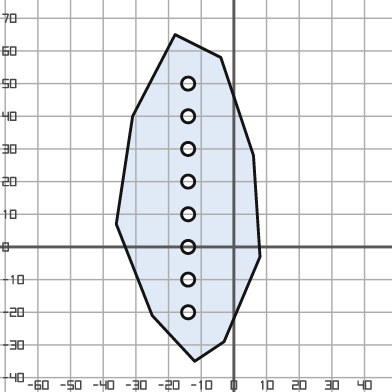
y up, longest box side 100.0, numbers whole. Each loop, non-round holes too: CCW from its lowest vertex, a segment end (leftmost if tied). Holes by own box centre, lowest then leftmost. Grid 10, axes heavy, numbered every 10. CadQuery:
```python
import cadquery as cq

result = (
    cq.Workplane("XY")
    .moveTo(-12.0, -35.0)
    .lineTo(-3.0, -29.0)
    .lineTo(8.0, -3.0)
    .lineTo(6.0, 28.0)
    .lineTo(-4.0, 58.0)
    .lineTo(-18.0, 65.0)
    .lineTo(-31.0, 40.0)
    .lineTo(-36.0, 7.0)
    .lineTo(-25.0, -21.0)
    .close()
    .moveTo(-14.0, -20.0)
    .circle(2.0)
    .moveTo(-14.0, -10.0)
    .circle(2.0)
    .moveTo(-14.0, 0.0)
    .circle(2.0)
    .moveTo(-14.0, 10.0)
    .circle(2.0)
    .moveTo(-14.0, 20.0)
    .circle(2.0)
    .moveTo(-14.0, 30.0)
    .circle(2.0)
    .moveTo(-14.0, 40.0)
    .circle(2.0)
    .moveTo(-14.0, 50.0)
    .circle(2.0)
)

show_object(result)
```